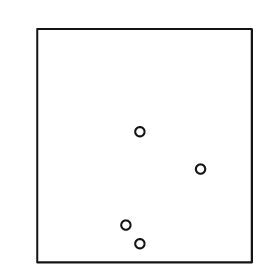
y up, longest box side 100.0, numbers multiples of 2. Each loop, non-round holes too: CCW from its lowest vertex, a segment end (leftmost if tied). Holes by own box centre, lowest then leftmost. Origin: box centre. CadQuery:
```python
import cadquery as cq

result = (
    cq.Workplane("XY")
    .moveTo(-46.0, -50.0)
    .lineTo(46.0, -50.0)
    .lineTo(46.0, 50.0)
    .lineTo(-46.0, 50.0)
    .close()
    .moveTo(-2.0, -42.0)
    .circle(2.0)
    .moveTo(-8.0, -34.0)
    .circle(2.0)
    .moveTo(24.0, -10.0)
    .circle(2.0)
    .moveTo(-2.0, 6.0)
    .circle(2.0)
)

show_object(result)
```